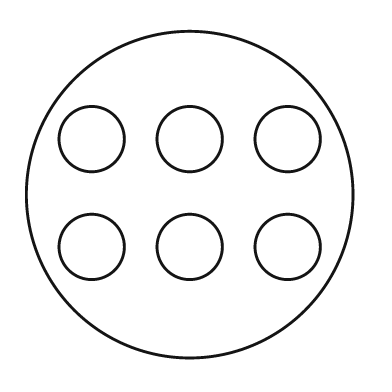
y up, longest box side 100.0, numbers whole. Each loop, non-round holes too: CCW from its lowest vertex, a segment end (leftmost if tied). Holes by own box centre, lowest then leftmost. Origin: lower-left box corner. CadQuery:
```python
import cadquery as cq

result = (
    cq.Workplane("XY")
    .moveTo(50.0, 50.0)
    .circle(50.0)
    .moveTo(20.0, 34.0)
    .circle(10.0)
    .moveTo(50.0, 34.0)
    .circle(10.0)
    .moveTo(80.0, 34.0)
    .circle(10.0)
    .moveTo(20.0, 67.0)
    .circle(10.0)
    .moveTo(50.0, 67.0)
    .circle(10.0)
    .moveTo(80.0, 67.0)
    .circle(10.0)
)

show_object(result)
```